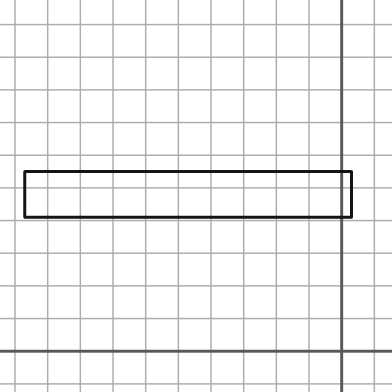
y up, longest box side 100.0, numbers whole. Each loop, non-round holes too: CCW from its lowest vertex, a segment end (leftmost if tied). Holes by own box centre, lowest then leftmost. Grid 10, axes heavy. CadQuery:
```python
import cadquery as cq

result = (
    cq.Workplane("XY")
    .moveTo(-97.0, 41.0)
    .lineTo(3.0, 41.0)
    .lineTo(3.0, 55.0)
    .lineTo(-97.0, 55.0)
    .close()
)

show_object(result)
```